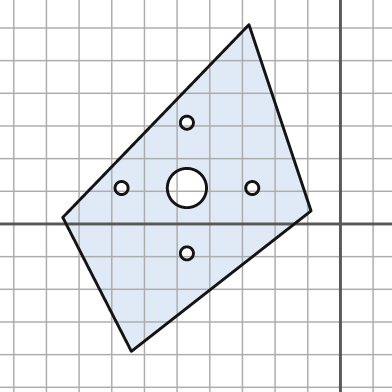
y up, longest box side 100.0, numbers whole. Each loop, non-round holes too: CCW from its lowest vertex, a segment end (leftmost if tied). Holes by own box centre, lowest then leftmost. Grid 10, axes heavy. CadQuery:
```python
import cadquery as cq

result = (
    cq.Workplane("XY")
    .moveTo(-64.0, -39.0)
    .lineTo(-9.0, 4.0)
    .lineTo(-28.0, 61.0)
    .lineTo(-85.0, 2.0)
    .close()
    .moveTo(-47.0, -9.0)
    .circle(2.0)
    .moveTo(-67.0, 11.0)
    .circle(2.0)
    .moveTo(-47.0, 11.0)
    .circle(6.0)
    .moveTo(-27.0, 11.0)
    .circle(2.0)
    .moveTo(-47.0, 31.0)
    .circle(2.0)
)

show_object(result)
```